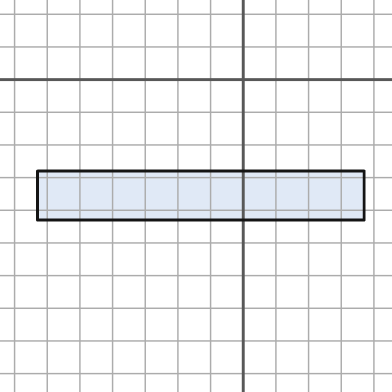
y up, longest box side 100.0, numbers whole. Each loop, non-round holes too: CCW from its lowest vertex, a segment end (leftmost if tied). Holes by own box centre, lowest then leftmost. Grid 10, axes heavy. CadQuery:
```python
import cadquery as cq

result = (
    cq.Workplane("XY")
    .moveTo(-63.0, -43.0)
    .lineTo(37.0, -43.0)
    .lineTo(37.0, -28.0)
    .lineTo(-63.0, -28.0)
    .close()
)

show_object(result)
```